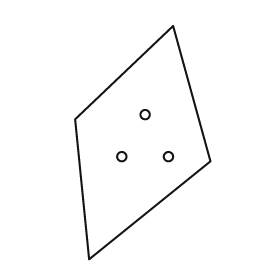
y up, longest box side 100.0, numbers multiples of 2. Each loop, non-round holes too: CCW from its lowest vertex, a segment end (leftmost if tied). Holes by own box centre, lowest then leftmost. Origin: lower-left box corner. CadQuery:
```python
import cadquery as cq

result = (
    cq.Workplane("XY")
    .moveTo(6.0, 0.0)
    .lineTo(58.0, 42.0)
    .lineTo(42.0, 100.0)
    .lineTo(0.0, 60.0)
    .close()
    .moveTo(20.0, 44.0)
    .circle(2.0)
    .moveTo(40.0, 44.0)
    .circle(2.0)
    .moveTo(30.0, 62.0)
    .circle(2.0)
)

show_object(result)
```